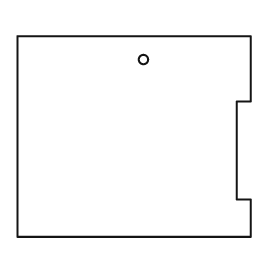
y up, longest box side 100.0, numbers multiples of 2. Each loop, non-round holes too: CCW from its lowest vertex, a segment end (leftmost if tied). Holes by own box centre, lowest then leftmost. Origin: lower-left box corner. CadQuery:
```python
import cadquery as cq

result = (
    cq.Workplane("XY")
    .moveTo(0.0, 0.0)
    .lineTo(100.0, 0.0)
    .lineTo(100.0, 16.0)
    .lineTo(94.0, 16.0)
    .lineTo(94.0, 58.0)
    .lineTo(100.0, 58.0)
    .lineTo(100.0, 86.0)
    .lineTo(0.0, 86.0)
    .close()
    .moveTo(54.0, 76.0)
    .circle(2.0)
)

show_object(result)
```